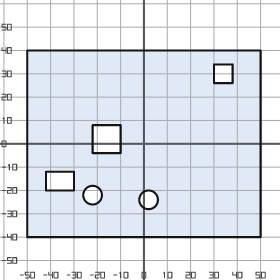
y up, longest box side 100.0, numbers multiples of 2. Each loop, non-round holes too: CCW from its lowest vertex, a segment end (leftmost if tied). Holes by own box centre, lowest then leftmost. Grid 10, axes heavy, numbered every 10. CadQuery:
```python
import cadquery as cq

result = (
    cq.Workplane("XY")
    .moveTo(-50.0, -40.0)
    .lineTo(50.0, -40.0)
    .lineTo(50.0, 40.0)
    .lineTo(-50.0, 40.0)
    .close()
    .moveTo(2.0, -24.0)
    .circle(4.0)
    .moveTo(-22.0, -22.0)
    .circle(4.0)
    .moveTo(-42.0, -20.0)
    .lineTo(-30.0, -20.0)
    .lineTo(-30.0, -12.0)
    .lineTo(-42.0, -12.0)
    .close()
    .moveTo(-22.0, -4.0)
    .lineTo(-10.0, -4.0)
    .lineTo(-10.0, 8.0)
    .lineTo(-22.0, 8.0)
    .close()
    .moveTo(30.0, 26.0)
    .lineTo(38.0, 26.0)
    .lineTo(38.0, 34.0)
    .lineTo(30.0, 34.0)
    .close()
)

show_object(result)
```